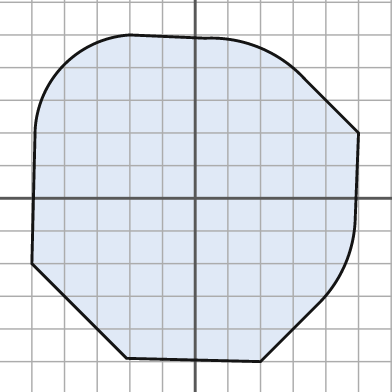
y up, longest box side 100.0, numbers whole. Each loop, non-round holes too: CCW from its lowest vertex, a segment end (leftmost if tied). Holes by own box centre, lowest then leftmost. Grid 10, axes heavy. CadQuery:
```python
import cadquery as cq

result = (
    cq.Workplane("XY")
    .moveTo(20.0, -50.0)
    .lineTo(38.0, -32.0)
    .threePointArc((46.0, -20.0), (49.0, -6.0))
    .lineTo(50.0, 20.0)
    .lineTo(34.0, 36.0)
    .threePointArc((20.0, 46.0), (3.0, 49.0))
    .lineTo(-20.0, 50.0)
    .threePointArc((-40.0, 41.0), (-49.0, 21.0))
    .lineTo(-50.0, -20.0)
    .lineTo(-21.0, -49.0)
    .close()
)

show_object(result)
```